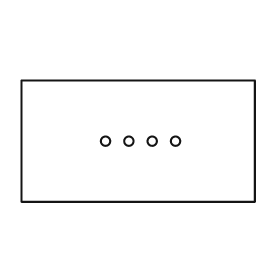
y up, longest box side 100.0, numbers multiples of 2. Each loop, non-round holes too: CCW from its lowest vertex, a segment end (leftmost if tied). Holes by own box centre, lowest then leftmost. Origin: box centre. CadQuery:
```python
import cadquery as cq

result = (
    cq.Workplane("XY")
    .moveTo(-50.0, -26.0)
    .lineTo(50.0, -26.0)
    .lineTo(50.0, 26.0)
    .lineTo(-50.0, 26.0)
    .close()
    .moveTo(-14.0, 0.0)
    .circle(2.0)
    .moveTo(-4.0, 0.0)
    .circle(2.0)
    .moveTo(6.0, 0.0)
    .circle(2.0)
    .moveTo(16.0, 0.0)
    .circle(2.0)
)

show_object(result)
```